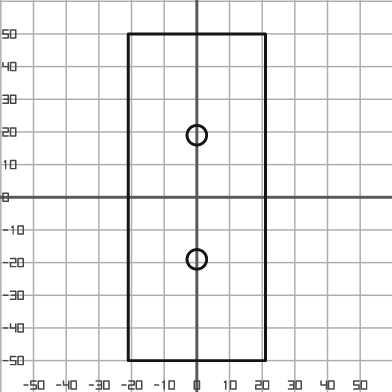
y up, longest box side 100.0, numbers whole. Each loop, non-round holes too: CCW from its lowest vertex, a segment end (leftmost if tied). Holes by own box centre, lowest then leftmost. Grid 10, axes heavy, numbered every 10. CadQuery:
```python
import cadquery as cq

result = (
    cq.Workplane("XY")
    .moveTo(-21.0, -50.0)
    .lineTo(21.0, -50.0)
    .lineTo(21.0, 50.0)
    .lineTo(-21.0, 50.0)
    .close()
    .moveTo(0.0, -19.0)
    .circle(3.0)
    .moveTo(0.0, 19.0)
    .circle(3.0)
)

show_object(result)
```